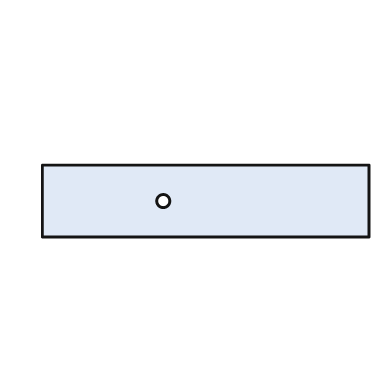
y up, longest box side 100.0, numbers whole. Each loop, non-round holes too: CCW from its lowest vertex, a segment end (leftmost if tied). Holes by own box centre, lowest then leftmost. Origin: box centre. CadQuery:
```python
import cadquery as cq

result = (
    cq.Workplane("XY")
    .moveTo(-50.0, -11.0)
    .lineTo(50.0, -11.0)
    .lineTo(50.0, 11.0)
    .lineTo(-50.0, 11.0)
    .close()
    .moveTo(-13.0, 0.0)
    .circle(2.0)
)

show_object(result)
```